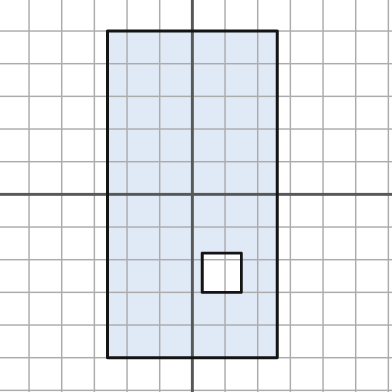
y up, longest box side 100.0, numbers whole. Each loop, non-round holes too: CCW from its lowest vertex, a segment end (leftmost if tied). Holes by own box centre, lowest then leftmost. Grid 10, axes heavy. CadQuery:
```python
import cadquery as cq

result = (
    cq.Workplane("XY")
    .moveTo(-26.0, -50.0)
    .lineTo(26.0, -50.0)
    .lineTo(26.0, 50.0)
    .lineTo(-26.0, 50.0)
    .close()
    .moveTo(3.0, -30.0)
    .lineTo(15.0, -30.0)
    .lineTo(15.0, -18.0)
    .lineTo(3.0, -18.0)
    .close()
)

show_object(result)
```